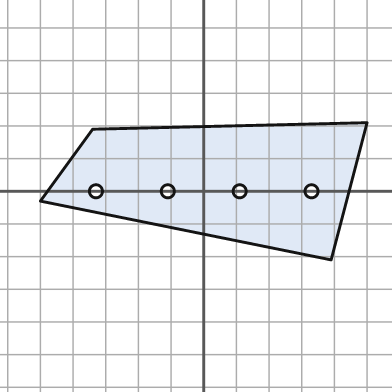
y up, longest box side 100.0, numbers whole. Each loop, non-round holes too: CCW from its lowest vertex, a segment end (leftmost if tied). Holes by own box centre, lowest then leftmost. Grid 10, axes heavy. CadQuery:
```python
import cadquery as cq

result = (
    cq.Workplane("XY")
    .moveTo(39.0, -21.0)
    .lineTo(50.0, 21.0)
    .lineTo(-34.0, 19.0)
    .lineTo(-50.0, -3.0)
    .close()
    .moveTo(-33.0, 0.0)
    .circle(2.0)
    .moveTo(-11.0, 0.0)
    .circle(2.0)
    .moveTo(11.0, 0.0)
    .circle(2.0)
    .moveTo(33.0, 0.0)
    .circle(2.0)
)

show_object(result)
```